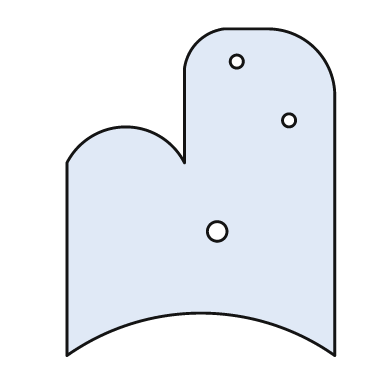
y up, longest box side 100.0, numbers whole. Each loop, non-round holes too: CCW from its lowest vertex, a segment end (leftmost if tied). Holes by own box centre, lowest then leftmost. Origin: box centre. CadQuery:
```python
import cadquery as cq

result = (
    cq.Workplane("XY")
    .moveTo(-41.0, -50.0)
    .threePointArc((0.0, -37.0), (41.0, -50.0))
    .lineTo(41.0, 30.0)
    .threePointArc((35.0, 44.0), (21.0, 50.0))
    .lineTo(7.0, 50.0)
    .threePointArc((-1.0, 46.0), (-5.0, 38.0))
    .lineTo(-5.0, 9.0)
    .threePointArc((-23.0, 20.0), (-41.0, 9.0))
    .close()
    .moveTo(5.0, -12.0)
    .circle(3.0)
    .moveTo(27.0, 22.0)
    .circle(2.0)
    .moveTo(11.0, 40.0)
    .circle(2.0)
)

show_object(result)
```